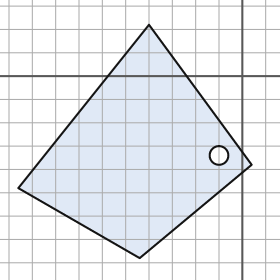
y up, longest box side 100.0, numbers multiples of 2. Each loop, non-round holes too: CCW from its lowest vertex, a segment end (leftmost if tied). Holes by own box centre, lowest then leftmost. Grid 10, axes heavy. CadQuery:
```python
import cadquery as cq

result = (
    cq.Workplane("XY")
    .moveTo(-44.0, -78.0)
    .lineTo(4.0, -38.0)
    .lineTo(-40.0, 22.0)
    .lineTo(-96.0, -48.0)
    .close()
    .moveTo(-10.0, -34.0)
    .circle(4.0)
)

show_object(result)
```